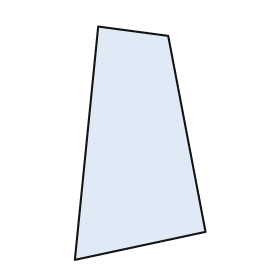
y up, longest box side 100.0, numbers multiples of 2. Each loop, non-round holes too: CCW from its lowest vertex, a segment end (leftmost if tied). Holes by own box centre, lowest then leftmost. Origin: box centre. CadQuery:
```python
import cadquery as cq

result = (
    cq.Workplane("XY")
    .moveTo(-28.0, -50.0)
    .lineTo(28.0, -38.0)
    .lineTo(12.0, 46.0)
    .lineTo(-18.0, 50.0)
    .close()
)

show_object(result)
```